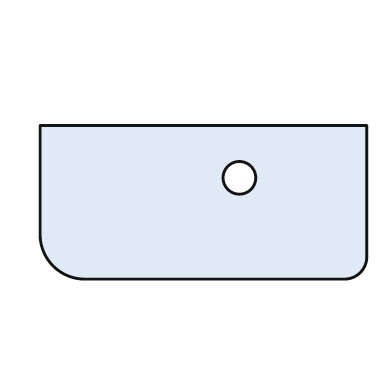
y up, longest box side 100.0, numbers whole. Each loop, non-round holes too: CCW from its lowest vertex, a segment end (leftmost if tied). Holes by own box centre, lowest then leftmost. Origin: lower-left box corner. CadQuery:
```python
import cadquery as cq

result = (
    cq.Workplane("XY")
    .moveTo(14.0, 0.0)
    .lineTo(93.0, 0.0)
    .threePointArc((98.0, 2.0), (100.0, 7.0))
    .lineTo(100.0, 47.0)
    .lineTo(0.0, 47.0)
    .lineTo(0.0, 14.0)
    .threePointArc((4.0, 4.0), (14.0, 0.0))
    .close()
    .moveTo(61.0, 31.0)
    .circle(5.0)
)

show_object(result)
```